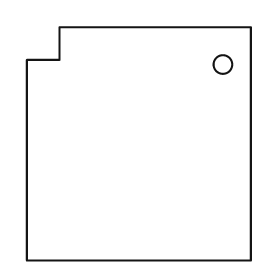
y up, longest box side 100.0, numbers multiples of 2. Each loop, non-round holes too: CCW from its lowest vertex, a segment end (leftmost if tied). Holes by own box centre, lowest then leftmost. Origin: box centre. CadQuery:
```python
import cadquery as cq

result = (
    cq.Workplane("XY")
    .moveTo(-48.0, -50.0)
    .lineTo(48.0, -50.0)
    .lineTo(48.0, 50.0)
    .lineTo(-34.0, 50.0)
    .lineTo(-34.0, 36.0)
    .lineTo(-48.0, 36.0)
    .close()
    .moveTo(36.0, 34.0)
    .circle(4.0)
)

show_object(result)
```